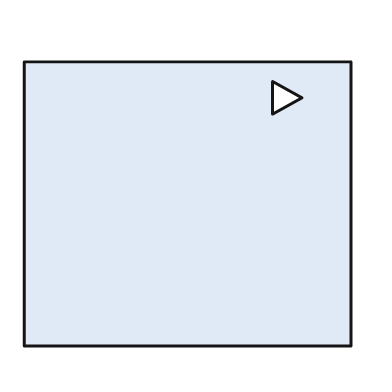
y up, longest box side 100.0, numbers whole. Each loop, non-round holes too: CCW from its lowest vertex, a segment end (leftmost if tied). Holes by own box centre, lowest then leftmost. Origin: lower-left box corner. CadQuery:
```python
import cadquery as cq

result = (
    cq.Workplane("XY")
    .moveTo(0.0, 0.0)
    .lineTo(100.0, 0.0)
    .lineTo(100.0, 87.0)
    .lineTo(0.0, 87.0)
    .close()
    .moveTo(76.0, 71.0)
    .lineTo(85.0, 76.0)
    .lineTo(76.0, 81.0)
    .close()
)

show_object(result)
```